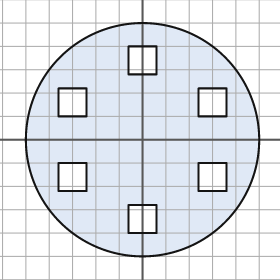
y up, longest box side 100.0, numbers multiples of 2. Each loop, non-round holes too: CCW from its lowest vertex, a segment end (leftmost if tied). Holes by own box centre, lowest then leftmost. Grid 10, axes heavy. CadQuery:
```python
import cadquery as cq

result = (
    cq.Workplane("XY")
    .moveTo(0.0, 0.0)
    .circle(50.0)
    .moveTo(-6.0, -40.0)
    .lineTo(6.0, -40.0)
    .lineTo(6.0, -28.0)
    .lineTo(-6.0, -28.0)
    .close()
    .moveTo(-36.0, -22.0)
    .lineTo(-24.0, -22.0)
    .lineTo(-24.0, -10.0)
    .lineTo(-36.0, -10.0)
    .close()
    .moveTo(24.0, -22.0)
    .lineTo(36.0, -22.0)
    .lineTo(36.0, -10.0)
    .lineTo(24.0, -10.0)
    .close()
    .moveTo(-36.0, 10.0)
    .lineTo(-24.0, 10.0)
    .lineTo(-24.0, 22.0)
    .lineTo(-36.0, 22.0)
    .close()
    .moveTo(24.0, 10.0)
    .lineTo(36.0, 10.0)
    .lineTo(36.0, 22.0)
    .lineTo(24.0, 22.0)
    .close()
    .moveTo(-6.0, 28.0)
    .lineTo(6.0, 28.0)
    .lineTo(6.0, 40.0)
    .lineTo(-6.0, 40.0)
    .close()
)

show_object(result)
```